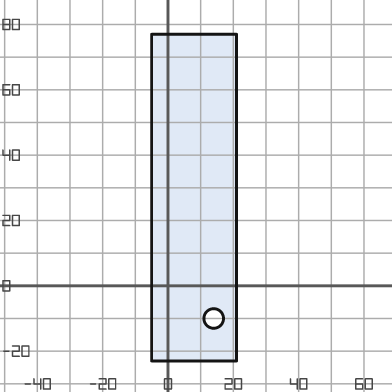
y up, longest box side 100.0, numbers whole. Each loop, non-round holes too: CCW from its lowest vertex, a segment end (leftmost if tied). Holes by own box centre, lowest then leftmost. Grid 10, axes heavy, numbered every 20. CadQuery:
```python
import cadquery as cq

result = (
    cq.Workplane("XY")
    .moveTo(-5.0, -23.0)
    .lineTo(21.0, -23.0)
    .lineTo(21.0, 77.0)
    .lineTo(-5.0, 77.0)
    .close()
    .moveTo(14.0, -10.0)
    .circle(3.0)
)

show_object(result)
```